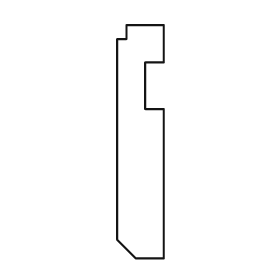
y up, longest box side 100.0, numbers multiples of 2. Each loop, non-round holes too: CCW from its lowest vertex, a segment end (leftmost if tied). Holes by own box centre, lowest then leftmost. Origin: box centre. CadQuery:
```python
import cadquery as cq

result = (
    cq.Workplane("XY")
    .moveTo(-2.0, -50.0)
    .lineTo(10.0, -50.0)
    .lineTo(10.0, 14.0)
    .lineTo(2.0, 14.0)
    .lineTo(2.0, 34.0)
    .lineTo(10.0, 34.0)
    .lineTo(10.0, 50.0)
    .lineTo(-6.0, 50.0)
    .lineTo(-6.0, 44.0)
    .lineTo(-10.0, 44.0)
    .lineTo(-10.0, -42.0)
    .close()
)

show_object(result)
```